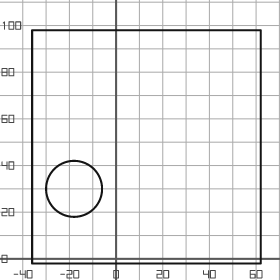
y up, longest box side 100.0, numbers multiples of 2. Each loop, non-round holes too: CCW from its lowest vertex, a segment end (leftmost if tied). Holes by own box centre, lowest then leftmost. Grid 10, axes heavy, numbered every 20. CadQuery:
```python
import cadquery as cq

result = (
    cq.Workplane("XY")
    .moveTo(-36.0, -2.0)
    .lineTo(62.0, -2.0)
    .lineTo(62.0, 98.0)
    .lineTo(-36.0, 98.0)
    .close()
    .moveTo(-18.0, 30.0)
    .circle(12.0)
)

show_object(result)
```